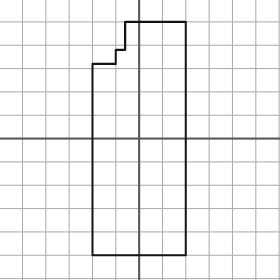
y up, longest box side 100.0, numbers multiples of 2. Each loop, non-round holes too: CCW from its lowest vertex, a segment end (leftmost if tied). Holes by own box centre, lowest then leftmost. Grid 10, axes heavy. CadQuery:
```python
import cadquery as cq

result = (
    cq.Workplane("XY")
    .moveTo(-20.0, -50.0)
    .lineTo(20.0, -50.0)
    .lineTo(20.0, 50.0)
    .lineTo(-6.0, 50.0)
    .lineTo(-6.0, 38.0)
    .lineTo(-10.0, 38.0)
    .lineTo(-10.0, 32.0)
    .lineTo(-20.0, 32.0)
    .close()
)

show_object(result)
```